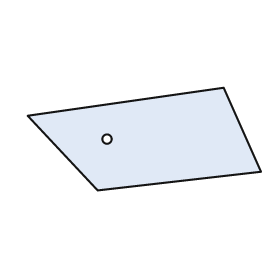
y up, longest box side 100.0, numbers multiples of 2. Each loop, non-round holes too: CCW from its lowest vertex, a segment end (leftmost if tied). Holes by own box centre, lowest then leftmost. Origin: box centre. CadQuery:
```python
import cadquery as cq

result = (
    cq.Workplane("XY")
    .moveTo(-20.0, -22.0)
    .lineTo(50.0, -14.0)
    .lineTo(34.0, 22.0)
    .lineTo(-50.0, 10.0)
    .close()
    .moveTo(-16.0, 0.0)
    .circle(2.0)
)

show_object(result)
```